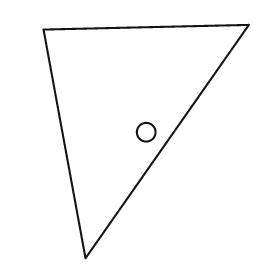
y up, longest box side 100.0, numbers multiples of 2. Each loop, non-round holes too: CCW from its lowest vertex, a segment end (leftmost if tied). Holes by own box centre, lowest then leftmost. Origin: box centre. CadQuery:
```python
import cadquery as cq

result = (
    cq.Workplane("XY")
    .moveTo(-26.0, -50.0)
    .lineTo(44.0, 50.0)
    .lineTo(-44.0, 48.0)
    .close()
    .moveTo(0.0, 4.0)
    .circle(4.0)
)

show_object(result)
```